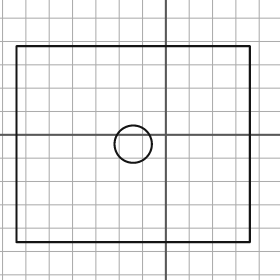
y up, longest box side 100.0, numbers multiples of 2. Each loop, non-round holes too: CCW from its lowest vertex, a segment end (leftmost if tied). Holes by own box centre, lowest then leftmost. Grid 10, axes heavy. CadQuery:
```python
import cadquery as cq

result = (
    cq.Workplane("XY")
    .moveTo(-64.0, -46.0)
    .lineTo(36.0, -46.0)
    .lineTo(36.0, 38.0)
    .lineTo(-64.0, 38.0)
    .close()
    .moveTo(-14.0, -4.0)
    .circle(8.0)
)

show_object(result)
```